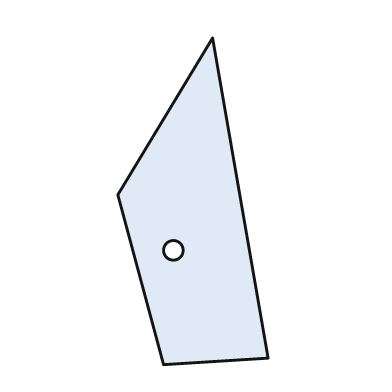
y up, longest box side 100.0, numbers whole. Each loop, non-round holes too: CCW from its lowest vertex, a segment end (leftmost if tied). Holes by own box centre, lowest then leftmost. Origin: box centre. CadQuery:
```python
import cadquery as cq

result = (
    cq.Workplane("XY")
    .moveTo(-9.0, -50.0)
    .lineTo(23.0, -48.0)
    .lineTo(6.0, 50.0)
    .lineTo(-23.0, 2.0)
    .close()
    .moveTo(-6.0, -15.0)
    .circle(3.0)
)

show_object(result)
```